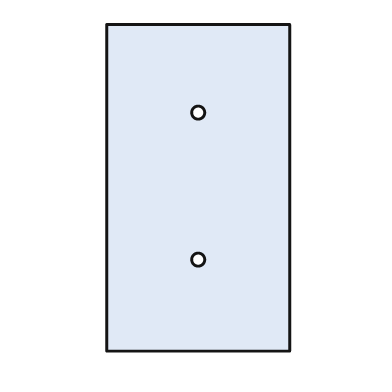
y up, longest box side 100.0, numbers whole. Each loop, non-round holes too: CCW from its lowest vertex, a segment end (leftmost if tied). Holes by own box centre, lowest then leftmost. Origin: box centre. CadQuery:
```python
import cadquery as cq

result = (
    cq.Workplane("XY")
    .moveTo(-28.0, -50.0)
    .lineTo(28.0, -50.0)
    .lineTo(28.0, 50.0)
    .lineTo(-28.0, 50.0)
    .close()
    .moveTo(0.0, -22.0)
    .circle(2.0)
    .moveTo(0.0, 23.0)
    .circle(2.0)
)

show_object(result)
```